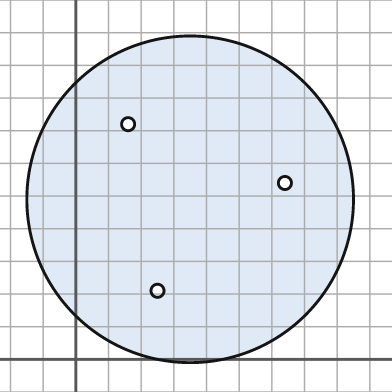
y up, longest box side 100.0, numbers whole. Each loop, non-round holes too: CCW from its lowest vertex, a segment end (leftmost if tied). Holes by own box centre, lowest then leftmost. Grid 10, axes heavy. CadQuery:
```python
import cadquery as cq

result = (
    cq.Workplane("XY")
    .moveTo(35.0, 49.0)
    .circle(50.0)
    .moveTo(25.0, 21.0)
    .circle(2.0)
    .moveTo(64.0, 54.0)
    .circle(2.0)
    .moveTo(16.0, 72.0)
    .circle(2.0)
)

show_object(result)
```